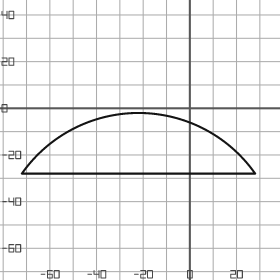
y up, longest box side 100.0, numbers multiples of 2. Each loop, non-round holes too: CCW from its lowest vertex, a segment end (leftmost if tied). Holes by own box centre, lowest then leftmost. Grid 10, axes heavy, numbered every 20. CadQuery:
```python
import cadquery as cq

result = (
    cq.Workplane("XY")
    .moveTo(-72.0, -28.0)
    .lineTo(28.0, -28.0)
    .threePointArc((-22.0, -2.0), (-72.0, -28.0))
    .close()
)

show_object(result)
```